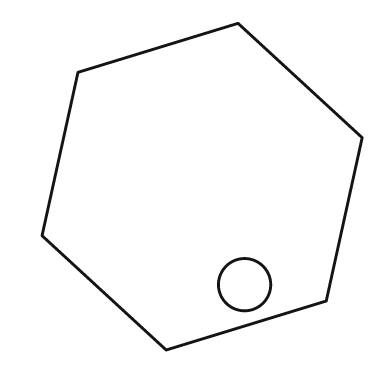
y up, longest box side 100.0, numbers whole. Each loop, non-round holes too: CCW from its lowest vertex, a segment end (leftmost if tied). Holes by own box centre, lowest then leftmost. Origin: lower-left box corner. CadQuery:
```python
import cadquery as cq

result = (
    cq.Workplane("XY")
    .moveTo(38.0, 0.0)
    .lineTo(87.0, 15.0)
    .lineTo(98.0, 65.0)
    .lineTo(60.0, 100.0)
    .lineTo(11.0, 85.0)
    .lineTo(0.0, 35.0)
    .close()
    .moveTo(62.0, 20.0)
    .circle(8.0)
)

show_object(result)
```